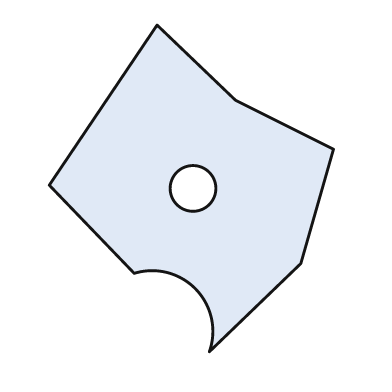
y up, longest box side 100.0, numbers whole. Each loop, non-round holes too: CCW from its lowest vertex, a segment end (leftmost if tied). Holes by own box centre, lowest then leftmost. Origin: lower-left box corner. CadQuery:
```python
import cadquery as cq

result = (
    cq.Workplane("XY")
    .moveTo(49.0, 0.0)
    .lineTo(77.0, 27.0)
    .lineTo(87.0, 62.0)
    .lineTo(57.0, 77.0)
    .lineTo(33.0, 100.0)
    .lineTo(0.0, 51.0)
    .lineTo(26.0, 24.0)
    .threePointArc((45.0, 19.0), (49.0, 0.0))
    .close()
    .moveTo(44.0, 50.0)
    .circle(7.0)
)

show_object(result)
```